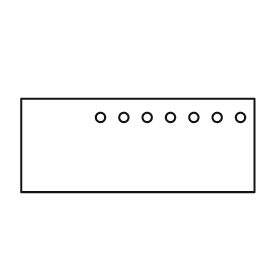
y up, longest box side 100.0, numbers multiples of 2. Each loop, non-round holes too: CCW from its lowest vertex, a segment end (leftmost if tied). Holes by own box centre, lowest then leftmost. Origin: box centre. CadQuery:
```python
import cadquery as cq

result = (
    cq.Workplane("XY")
    .moveTo(-50.0, -20.0)
    .lineTo(50.0, -20.0)
    .lineTo(50.0, 20.0)
    .lineTo(-50.0, 20.0)
    .close()
    .moveTo(-16.0, 12.0)
    .circle(2.0)
    .moveTo(-6.0, 12.0)
    .circle(2.0)
    .moveTo(4.0, 12.0)
    .circle(2.0)
    .moveTo(14.0, 12.0)
    .circle(2.0)
    .moveTo(24.0, 12.0)
    .circle(2.0)
    .moveTo(34.0, 12.0)
    .circle(2.0)
    .moveTo(44.0, 12.0)
    .circle(2.0)
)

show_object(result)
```